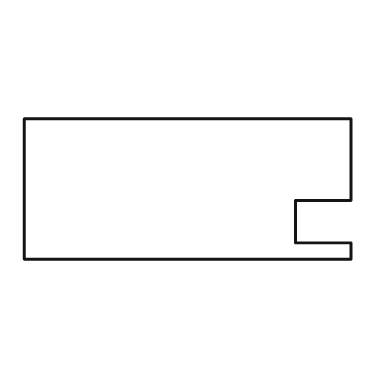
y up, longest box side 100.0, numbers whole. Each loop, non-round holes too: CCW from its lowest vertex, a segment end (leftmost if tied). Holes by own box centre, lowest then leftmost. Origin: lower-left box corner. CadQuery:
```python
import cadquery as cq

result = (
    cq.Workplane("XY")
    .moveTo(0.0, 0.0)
    .lineTo(100.0, 0.0)
    .lineTo(100.0, 5.0)
    .lineTo(83.0, 5.0)
    .lineTo(83.0, 18.0)
    .lineTo(100.0, 18.0)
    .lineTo(100.0, 43.0)
    .lineTo(0.0, 43.0)
    .close()
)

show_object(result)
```